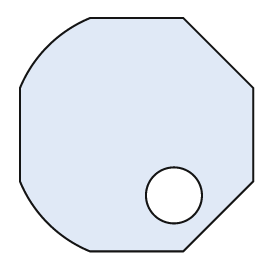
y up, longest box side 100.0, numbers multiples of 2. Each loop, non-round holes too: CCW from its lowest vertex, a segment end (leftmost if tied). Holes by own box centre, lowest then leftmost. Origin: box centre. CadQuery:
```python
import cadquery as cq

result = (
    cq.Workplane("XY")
    .moveTo(-20.0, -50.0)
    .lineTo(20.0, -50.0)
    .lineTo(50.0, -20.0)
    .lineTo(50.0, 20.0)
    .lineTo(20.0, 50.0)
    .lineTo(-20.0, 50.0)
    .threePointArc((-38.0, 38.0), (-50.0, 20.0))
    .lineTo(-50.0, -20.0)
    .threePointArc((-38.0, -38.0), (-20.0, -50.0))
    .close()
    .moveTo(16.0, -26.0)
    .circle(12.0)
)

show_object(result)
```